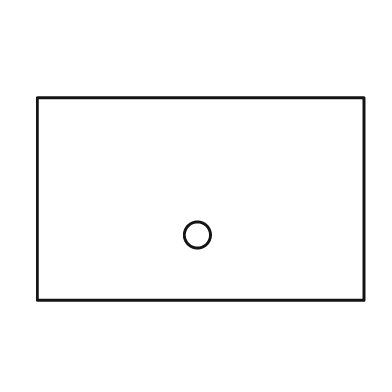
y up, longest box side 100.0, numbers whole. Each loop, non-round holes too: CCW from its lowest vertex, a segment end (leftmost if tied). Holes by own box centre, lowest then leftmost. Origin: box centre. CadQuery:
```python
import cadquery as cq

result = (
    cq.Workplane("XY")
    .moveTo(-50.0, -31.0)
    .lineTo(50.0, -31.0)
    .lineTo(50.0, 31.0)
    .lineTo(-50.0, 31.0)
    .close()
    .moveTo(-1.0, -11.0)
    .circle(4.0)
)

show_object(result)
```